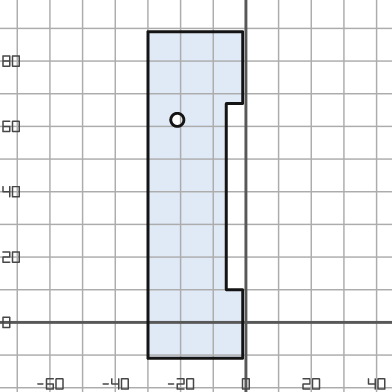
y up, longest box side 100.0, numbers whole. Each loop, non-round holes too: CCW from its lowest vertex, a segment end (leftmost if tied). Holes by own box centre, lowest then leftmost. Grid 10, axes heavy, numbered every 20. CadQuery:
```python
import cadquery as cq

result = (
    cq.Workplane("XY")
    .moveTo(-30.0, -11.0)
    .lineTo(-1.0, -11.0)
    .lineTo(-1.0, 10.0)
    .lineTo(-6.0, 10.0)
    .lineTo(-6.0, 67.0)
    .lineTo(-1.0, 67.0)
    .lineTo(-1.0, 89.0)
    .lineTo(-30.0, 89.0)
    .close()
    .moveTo(-21.0, 62.0)
    .circle(2.0)
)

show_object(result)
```